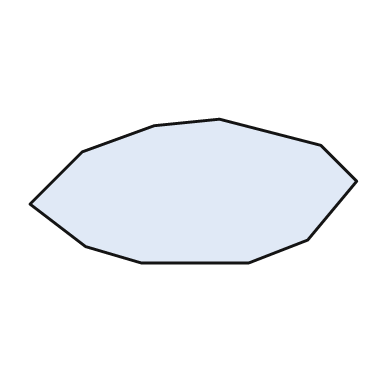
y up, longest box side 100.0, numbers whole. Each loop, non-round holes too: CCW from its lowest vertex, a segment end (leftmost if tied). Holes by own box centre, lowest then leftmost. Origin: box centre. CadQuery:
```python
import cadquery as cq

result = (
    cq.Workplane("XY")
    .moveTo(-16.0, -22.0)
    .lineTo(17.0, -22.0)
    .lineTo(35.0, -15.0)
    .lineTo(50.0, 3.0)
    .lineTo(39.0, 14.0)
    .lineTo(8.0, 22.0)
    .lineTo(-12.0, 20.0)
    .lineTo(-34.0, 12.0)
    .lineTo(-50.0, -4.0)
    .lineTo(-33.0, -17.0)
    .close()
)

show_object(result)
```